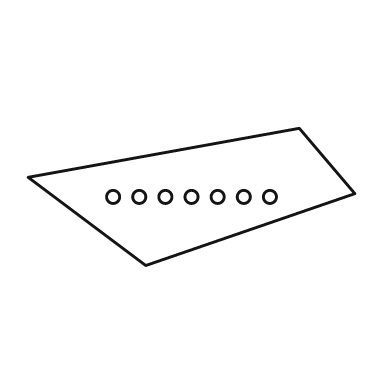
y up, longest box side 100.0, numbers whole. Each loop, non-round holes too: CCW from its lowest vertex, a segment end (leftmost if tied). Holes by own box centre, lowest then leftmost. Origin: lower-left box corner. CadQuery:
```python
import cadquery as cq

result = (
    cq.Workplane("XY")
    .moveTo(36.0, 0.0)
    .lineTo(100.0, 22.0)
    .lineTo(83.0, 42.0)
    .lineTo(0.0, 27.0)
    .close()
    .moveTo(26.0, 21.0)
    .circle(2.0)
    .moveTo(34.0, 21.0)
    .circle(2.0)
    .moveTo(42.0, 21.0)
    .circle(2.0)
    .moveTo(50.0, 21.0)
    .circle(2.0)
    .moveTo(58.0, 21.0)
    .circle(2.0)
    .moveTo(66.0, 21.0)
    .circle(2.0)
    .moveTo(74.0, 21.0)
    .circle(2.0)
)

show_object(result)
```